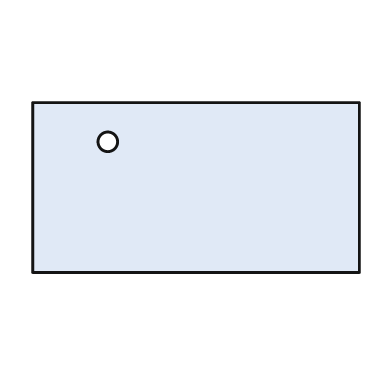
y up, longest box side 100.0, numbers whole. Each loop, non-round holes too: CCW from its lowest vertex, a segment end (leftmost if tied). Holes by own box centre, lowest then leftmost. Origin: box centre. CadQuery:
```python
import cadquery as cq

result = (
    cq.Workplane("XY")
    .moveTo(-50.0, -26.0)
    .lineTo(50.0, -26.0)
    .lineTo(50.0, 26.0)
    .lineTo(-50.0, 26.0)
    .close()
    .moveTo(-27.0, 14.0)
    .circle(3.0)
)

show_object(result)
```